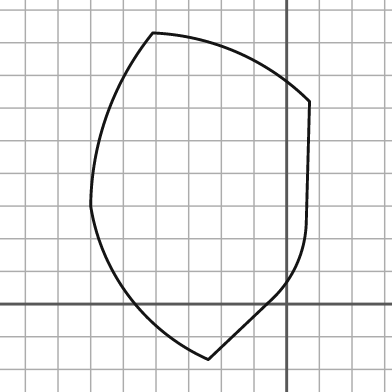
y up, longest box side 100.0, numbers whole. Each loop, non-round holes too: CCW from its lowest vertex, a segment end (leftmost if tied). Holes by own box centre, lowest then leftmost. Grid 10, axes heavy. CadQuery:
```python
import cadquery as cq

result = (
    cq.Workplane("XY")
    .moveTo(-24.0, -17.0)
    .lineTo(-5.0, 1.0)
    .threePointArc((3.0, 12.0), (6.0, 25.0))
    .lineTo(7.0, 62.0)
    .threePointArc((-15.0, 77.0), (-41.0, 83.0))
    .threePointArc((-55.0, 58.0), (-60.0, 30.0))
    .threePointArc((-48.0, 2.0), (-24.0, -17.0))
    .close()
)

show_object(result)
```